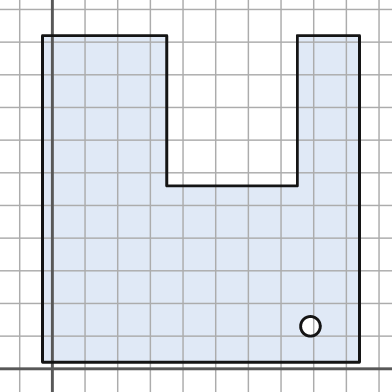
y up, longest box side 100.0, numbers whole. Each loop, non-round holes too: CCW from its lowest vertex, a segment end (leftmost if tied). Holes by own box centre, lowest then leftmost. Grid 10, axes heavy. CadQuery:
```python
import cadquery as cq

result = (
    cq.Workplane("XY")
    .moveTo(-3.0, 2.0)
    .lineTo(94.0, 2.0)
    .lineTo(94.0, 102.0)
    .lineTo(75.0, 102.0)
    .lineTo(75.0, 56.0)
    .lineTo(35.0, 56.0)
    .lineTo(35.0, 102.0)
    .lineTo(-3.0, 102.0)
    .close()
    .moveTo(79.0, 13.0)
    .circle(3.0)
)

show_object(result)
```